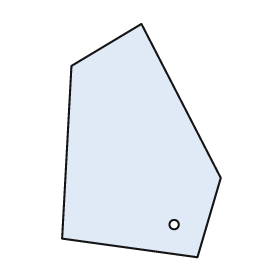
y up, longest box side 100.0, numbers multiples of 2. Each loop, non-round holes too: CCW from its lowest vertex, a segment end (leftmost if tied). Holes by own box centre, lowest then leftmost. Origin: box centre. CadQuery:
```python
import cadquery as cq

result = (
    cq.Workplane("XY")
    .moveTo(24.0, -50.0)
    .lineTo(34.0, -16.0)
    .lineTo(0.0, 50.0)
    .lineTo(-30.0, 32.0)
    .lineTo(-34.0, -42.0)
    .close()
    .moveTo(14.0, -36.0)
    .circle(2.0)
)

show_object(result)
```